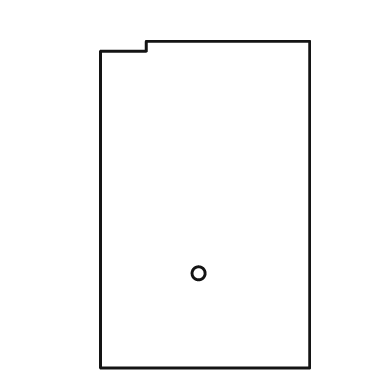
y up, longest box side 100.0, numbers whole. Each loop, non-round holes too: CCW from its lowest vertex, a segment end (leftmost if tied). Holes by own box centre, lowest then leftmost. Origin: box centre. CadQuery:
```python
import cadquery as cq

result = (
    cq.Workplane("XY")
    .moveTo(-32.0, -50.0)
    .lineTo(32.0, -50.0)
    .lineTo(32.0, 50.0)
    .lineTo(-18.0, 50.0)
    .lineTo(-18.0, 47.0)
    .lineTo(-32.0, 47.0)
    .close()
    .moveTo(-2.0, -21.0)
    .circle(2.0)
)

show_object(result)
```